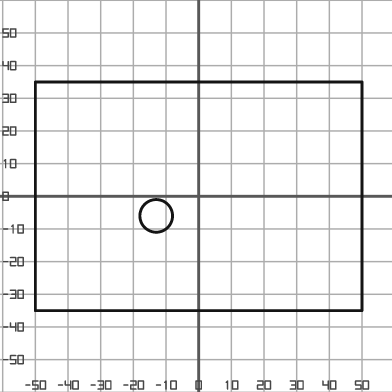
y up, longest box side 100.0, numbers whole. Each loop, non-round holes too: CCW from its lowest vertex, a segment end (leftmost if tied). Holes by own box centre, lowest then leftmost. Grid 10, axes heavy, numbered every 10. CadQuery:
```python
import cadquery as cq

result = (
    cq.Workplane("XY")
    .moveTo(-50.0, -35.0)
    .lineTo(50.0, -35.0)
    .lineTo(50.0, 35.0)
    .lineTo(-50.0, 35.0)
    .close()
    .moveTo(-13.0, -6.0)
    .circle(5.0)
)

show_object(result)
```